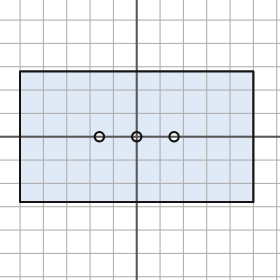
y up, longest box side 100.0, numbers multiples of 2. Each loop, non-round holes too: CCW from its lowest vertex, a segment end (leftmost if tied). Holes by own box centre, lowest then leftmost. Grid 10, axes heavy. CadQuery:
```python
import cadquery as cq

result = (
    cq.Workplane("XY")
    .moveTo(-50.0, -28.0)
    .lineTo(50.0, -28.0)
    .lineTo(50.0, 28.0)
    .lineTo(-50.0, 28.0)
    .close()
    .moveTo(-16.0, 0.0)
    .circle(2.0)
    .moveTo(0.0, 0.0)
    .circle(2.0)
    .moveTo(16.0, 0.0)
    .circle(2.0)
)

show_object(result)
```